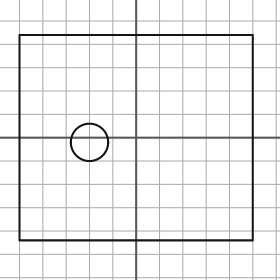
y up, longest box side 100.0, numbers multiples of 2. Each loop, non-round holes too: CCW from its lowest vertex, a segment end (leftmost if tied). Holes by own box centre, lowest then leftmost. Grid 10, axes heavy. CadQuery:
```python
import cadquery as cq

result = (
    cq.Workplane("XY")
    .moveTo(-50.0, -44.0)
    .lineTo(50.0, -44.0)
    .lineTo(50.0, 44.0)
    .lineTo(-50.0, 44.0)
    .close()
    .moveTo(-20.0, -2.0)
    .circle(8.0)
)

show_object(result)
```